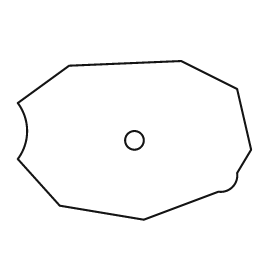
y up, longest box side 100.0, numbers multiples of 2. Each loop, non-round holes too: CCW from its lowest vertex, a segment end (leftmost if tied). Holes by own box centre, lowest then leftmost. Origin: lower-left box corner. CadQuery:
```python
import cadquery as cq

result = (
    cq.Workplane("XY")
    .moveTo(54.0, 0.0)
    .lineTo(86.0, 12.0)
    .threePointArc((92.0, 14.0), (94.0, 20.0))
    .lineTo(100.0, 30.0)
    .lineTo(94.0, 56.0)
    .lineTo(70.0, 68.0)
    .lineTo(22.0, 66.0)
    .lineTo(0.0, 50.0)
    .threePointArc((4.0, 38.0), (0.0, 26.0))
    .lineTo(18.0, 6.0)
    .close()
    .moveTo(50.0, 34.0)
    .circle(4.0)
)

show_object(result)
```